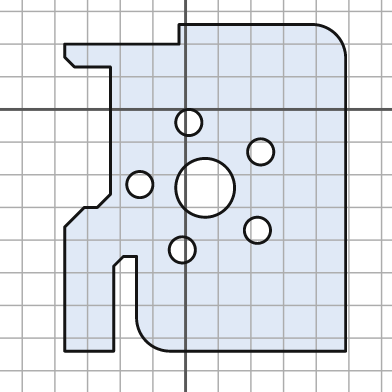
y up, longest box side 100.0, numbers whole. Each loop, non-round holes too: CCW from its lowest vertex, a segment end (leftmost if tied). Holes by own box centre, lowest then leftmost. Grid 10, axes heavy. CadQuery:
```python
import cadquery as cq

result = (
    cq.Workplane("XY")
    .moveTo(-37.0, -74.0)
    .lineTo(-22.0, -74.0)
    .lineTo(-22.0, -48.0)
    .lineTo(-19.0, -45.0)
    .lineTo(-15.0, -45.0)
    .lineTo(-15.0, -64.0)
    .threePointArc((-12.0, -71.0), (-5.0, -74.0))
    .lineTo(49.0, -74.0)
    .lineTo(49.0, 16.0)
    .threePointArc((46.0, 23.0), (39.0, 26.0))
    .lineTo(-2.0, 26.0)
    .lineTo(-2.0, 20.0)
    .lineTo(-37.0, 20.0)
    .lineTo(-37.0, 16.0)
    .lineTo(-34.0, 13.0)
    .lineTo(-23.0, 13.0)
    .lineTo(-23.0, -26.0)
    .lineTo(-27.0, -30.0)
    .lineTo(-31.0, -30.0)
    .lineTo(-37.0, -36.0)
    .close()
    .moveTo(-1.0, -43.0)
    .circle(4.0)
    .moveTo(22.0, -37.0)
    .circle(4.0)
    .moveTo(6.0, -24.0)
    .circle(9.0)
    .moveTo(-14.0, -23.0)
    .circle(4.0)
    .moveTo(23.0, -13.0)
    .circle(4.0)
    .moveTo(1.0, -4.0)
    .circle(4.0)
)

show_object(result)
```